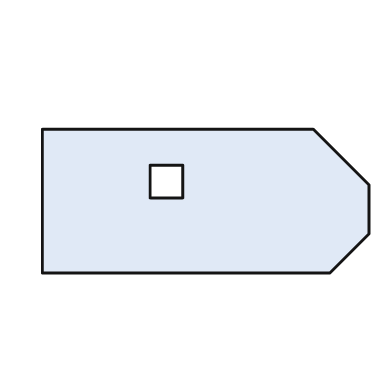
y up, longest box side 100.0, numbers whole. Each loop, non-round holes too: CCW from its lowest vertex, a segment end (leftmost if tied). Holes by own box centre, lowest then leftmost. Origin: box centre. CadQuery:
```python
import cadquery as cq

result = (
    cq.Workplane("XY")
    .moveTo(-50.0, -22.0)
    .lineTo(38.0, -22.0)
    .lineTo(50.0, -10.0)
    .lineTo(50.0, 5.0)
    .lineTo(33.0, 22.0)
    .lineTo(-50.0, 22.0)
    .close()
    .moveTo(-17.0, 1.0)
    .lineTo(-7.0, 1.0)
    .lineTo(-7.0, 11.0)
    .lineTo(-17.0, 11.0)
    .close()
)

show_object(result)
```